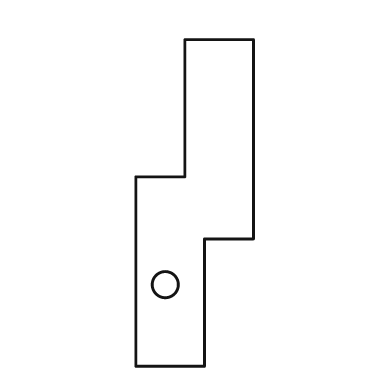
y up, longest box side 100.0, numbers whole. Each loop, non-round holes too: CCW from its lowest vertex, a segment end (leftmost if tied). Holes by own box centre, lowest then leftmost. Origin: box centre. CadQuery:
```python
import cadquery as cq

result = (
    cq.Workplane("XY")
    .moveTo(-18.0, -50.0)
    .lineTo(3.0, -50.0)
    .lineTo(3.0, -11.0)
    .lineTo(18.0, -11.0)
    .lineTo(18.0, 50.0)
    .lineTo(-3.0, 50.0)
    .lineTo(-3.0, 8.0)
    .lineTo(-18.0, 8.0)
    .close()
    .moveTo(-9.0, -25.0)
    .circle(4.0)
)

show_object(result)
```